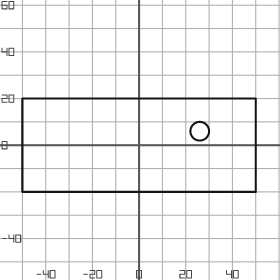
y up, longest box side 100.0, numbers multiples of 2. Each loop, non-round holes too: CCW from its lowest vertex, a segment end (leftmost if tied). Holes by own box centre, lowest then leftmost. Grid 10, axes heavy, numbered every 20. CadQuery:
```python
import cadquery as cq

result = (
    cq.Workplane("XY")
    .moveTo(-50.0, -20.0)
    .lineTo(50.0, -20.0)
    .lineTo(50.0, 20.0)
    .lineTo(-50.0, 20.0)
    .close()
    .moveTo(26.0, 6.0)
    .circle(4.0)
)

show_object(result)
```